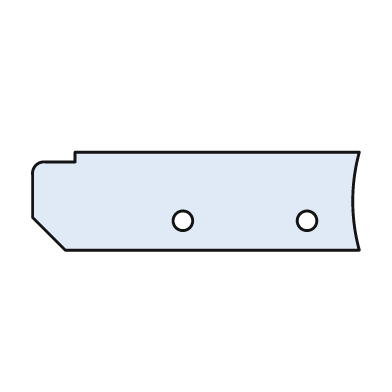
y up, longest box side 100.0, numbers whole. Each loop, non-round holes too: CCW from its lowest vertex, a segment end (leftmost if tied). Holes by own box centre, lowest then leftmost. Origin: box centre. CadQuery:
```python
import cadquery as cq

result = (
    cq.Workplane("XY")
    .moveTo(-40.0, -15.0)
    .lineTo(50.0, -15.0)
    .threePointArc((48.0, 0.0), (50.0, 15.0))
    .lineTo(-37.0, 15.0)
    .lineTo(-37.0, 12.0)
    .lineTo(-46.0, 12.0)
    .threePointArc((-49.0, 11.0), (-50.0, 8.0))
    .lineTo(-50.0, -5.0)
    .close()
    .moveTo(-4.0, -6.0)
    .circle(3.0)
    .moveTo(34.0, -6.0)
    .circle(3.0)
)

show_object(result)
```